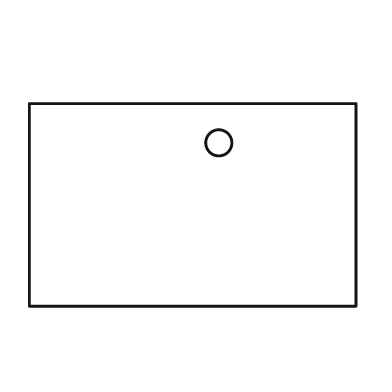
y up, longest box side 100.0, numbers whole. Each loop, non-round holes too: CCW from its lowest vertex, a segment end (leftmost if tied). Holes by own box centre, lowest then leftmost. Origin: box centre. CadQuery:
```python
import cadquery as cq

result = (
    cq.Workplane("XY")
    .moveTo(-50.0, -31.0)
    .lineTo(50.0, -31.0)
    .lineTo(50.0, 31.0)
    .lineTo(-50.0, 31.0)
    .close()
    .moveTo(8.0, 19.0)
    .circle(4.0)
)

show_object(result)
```